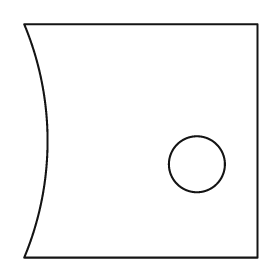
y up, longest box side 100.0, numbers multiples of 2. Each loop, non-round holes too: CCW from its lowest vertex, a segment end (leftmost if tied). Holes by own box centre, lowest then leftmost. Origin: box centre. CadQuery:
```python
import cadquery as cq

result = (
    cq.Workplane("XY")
    .moveTo(-50.0, -50.0)
    .lineTo(50.0, -50.0)
    .lineTo(50.0, 50.0)
    .lineTo(-50.0, 50.0)
    .threePointArc((-40.0, 0.0), (-50.0, -50.0))
    .close()
    .moveTo(24.0, -10.0)
    .circle(12.0)
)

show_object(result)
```